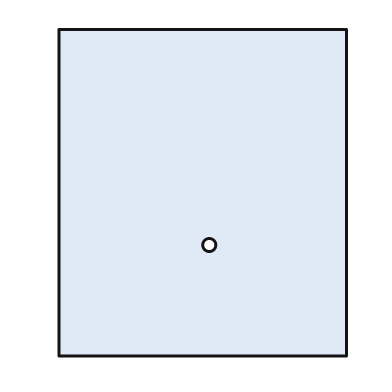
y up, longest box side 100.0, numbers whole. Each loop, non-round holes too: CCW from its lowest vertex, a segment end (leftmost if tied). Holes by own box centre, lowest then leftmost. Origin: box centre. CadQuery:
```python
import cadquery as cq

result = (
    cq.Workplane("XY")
    .moveTo(-44.0, -50.0)
    .lineTo(44.0, -50.0)
    .lineTo(44.0, 50.0)
    .lineTo(-44.0, 50.0)
    .close()
    .moveTo(2.0, -16.0)
    .circle(2.0)
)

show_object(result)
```